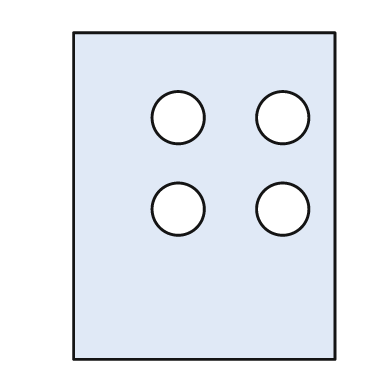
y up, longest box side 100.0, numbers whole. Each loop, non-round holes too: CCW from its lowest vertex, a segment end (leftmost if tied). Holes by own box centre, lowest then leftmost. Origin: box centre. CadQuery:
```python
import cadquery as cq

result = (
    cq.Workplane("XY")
    .moveTo(-40.0, -50.0)
    .lineTo(40.0, -50.0)
    .lineTo(40.0, 50.0)
    .lineTo(-40.0, 50.0)
    .close()
    .moveTo(-8.0, -4.0)
    .circle(8.0)
    .moveTo(24.0, -4.0)
    .circle(8.0)
    .moveTo(-8.0, 24.0)
    .circle(8.0)
    .moveTo(24.0, 24.0)
    .circle(8.0)
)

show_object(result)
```